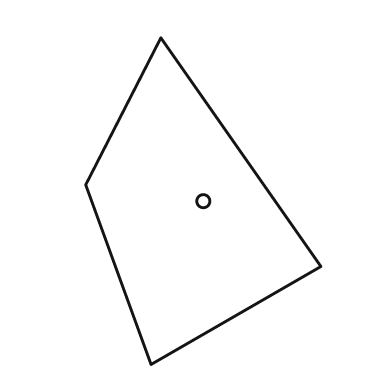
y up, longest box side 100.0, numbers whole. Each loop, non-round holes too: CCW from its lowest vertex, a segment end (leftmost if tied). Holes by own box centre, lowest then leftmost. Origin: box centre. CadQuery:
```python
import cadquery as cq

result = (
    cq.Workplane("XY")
    .moveTo(-16.0, -50.0)
    .lineTo(36.0, -20.0)
    .lineTo(-13.0, 50.0)
    .lineTo(-36.0, 5.0)
    .close()
    .moveTo(0.0, 0.0)
    .circle(2.0)
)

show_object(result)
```